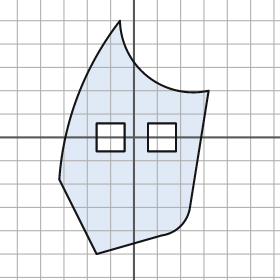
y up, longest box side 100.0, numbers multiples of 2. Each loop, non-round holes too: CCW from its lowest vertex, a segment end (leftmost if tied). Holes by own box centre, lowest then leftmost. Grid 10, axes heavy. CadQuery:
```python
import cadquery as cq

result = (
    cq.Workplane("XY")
    .moveTo(-16.0, -50.0)
    .lineTo(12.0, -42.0)
    .threePointArc((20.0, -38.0), (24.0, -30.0))
    .lineTo(32.0, 20.0)
    .threePointArc((6.0, 26.0), (-6.0, 50.0))
    .threePointArc((-24.0, 18.0), (-32.0, -18.0))
    .close()
    .moveTo(-16.0, -6.0)
    .lineTo(-4.0, -6.0)
    .lineTo(-4.0, 6.0)
    .lineTo(-16.0, 6.0)
    .close()
    .moveTo(6.0, -6.0)
    .lineTo(18.0, -6.0)
    .lineTo(18.0, 6.0)
    .lineTo(6.0, 6.0)
    .close()
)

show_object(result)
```